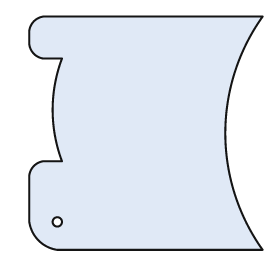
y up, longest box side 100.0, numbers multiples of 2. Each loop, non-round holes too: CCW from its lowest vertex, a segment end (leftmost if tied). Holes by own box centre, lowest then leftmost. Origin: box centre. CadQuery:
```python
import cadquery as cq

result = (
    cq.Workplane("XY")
    .moveTo(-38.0, -50.0)
    .lineTo(50.0, -50.0)
    .threePointArc((34.0, 0.0), (50.0, 50.0))
    .lineTo(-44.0, 50.0)
    .threePointArc((-48.0, 48.0), (-50.0, 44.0))
    .lineTo(-50.0, 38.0)
    .threePointArc((-48.0, 34.0), (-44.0, 32.0))
    .lineTo(-36.0, 32.0)
    .threePointArc((-40.0, 10.0), (-36.0, -12.0))
    .lineTo(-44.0, -12.0)
    .threePointArc((-48.0, -14.0), (-50.0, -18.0))
    .lineTo(-50.0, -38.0)
    .threePointArc((-46.0, -46.0), (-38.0, -50.0))
    .close()
    .moveTo(-38.0, -38.0)
    .circle(2.0)
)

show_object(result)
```